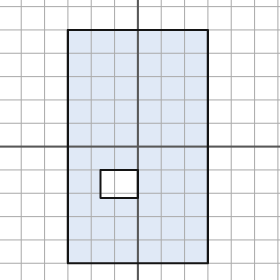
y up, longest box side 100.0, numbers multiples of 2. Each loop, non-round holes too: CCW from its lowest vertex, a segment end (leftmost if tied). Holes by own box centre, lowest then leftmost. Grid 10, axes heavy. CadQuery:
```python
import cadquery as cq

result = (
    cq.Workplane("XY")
    .moveTo(-30.0, -50.0)
    .lineTo(30.0, -50.0)
    .lineTo(30.0, 50.0)
    .lineTo(-30.0, 50.0)
    .close()
    .moveTo(-16.0, -22.0)
    .lineTo(0.0, -22.0)
    .lineTo(0.0, -10.0)
    .lineTo(-16.0, -10.0)
    .close()
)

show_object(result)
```